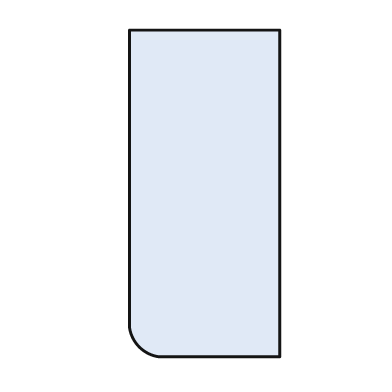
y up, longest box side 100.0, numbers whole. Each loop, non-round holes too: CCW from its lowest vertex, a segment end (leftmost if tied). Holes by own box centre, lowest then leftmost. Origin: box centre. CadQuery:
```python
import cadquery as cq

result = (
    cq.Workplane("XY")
    .moveTo(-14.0, -50.0)
    .lineTo(23.0, -50.0)
    .lineTo(23.0, 50.0)
    .lineTo(-23.0, 50.0)
    .lineTo(-23.0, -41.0)
    .threePointArc((-20.0, -47.0), (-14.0, -50.0))
    .close()
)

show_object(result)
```